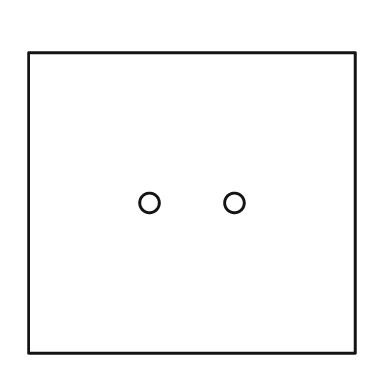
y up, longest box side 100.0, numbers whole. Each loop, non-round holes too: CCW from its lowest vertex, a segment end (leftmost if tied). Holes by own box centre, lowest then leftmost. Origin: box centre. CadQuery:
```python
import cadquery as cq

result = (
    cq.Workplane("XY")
    .moveTo(-50.0, -46.0)
    .lineTo(50.0, -46.0)
    .lineTo(50.0, 46.0)
    .lineTo(-50.0, 46.0)
    .close()
    .moveTo(-13.0, 0.0)
    .circle(3.0)
    .moveTo(13.0, 0.0)
    .circle(3.0)
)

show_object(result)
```